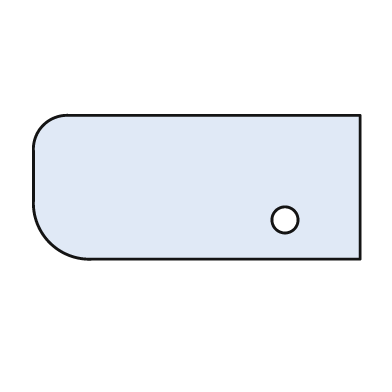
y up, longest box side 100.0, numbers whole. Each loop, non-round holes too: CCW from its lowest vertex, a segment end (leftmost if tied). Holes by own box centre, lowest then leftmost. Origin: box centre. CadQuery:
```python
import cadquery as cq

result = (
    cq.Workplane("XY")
    .moveTo(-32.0, -22.0)
    .lineTo(50.0, -22.0)
    .lineTo(50.0, 22.0)
    .lineTo(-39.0, 22.0)
    .threePointArc((-47.0, 19.0), (-50.0, 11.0))
    .lineTo(-50.0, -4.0)
    .threePointArc((-45.0, -17.0), (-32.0, -22.0))
    .close()
    .moveTo(27.0, -10.0)
    .circle(4.0)
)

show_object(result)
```